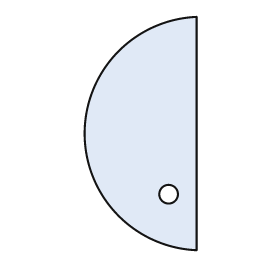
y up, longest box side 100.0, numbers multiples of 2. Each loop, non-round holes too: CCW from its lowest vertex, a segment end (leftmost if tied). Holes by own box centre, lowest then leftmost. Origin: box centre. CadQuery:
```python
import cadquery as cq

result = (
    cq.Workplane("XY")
    .moveTo(24.0, -50.0)
    .lineTo(24.0, 50.0)
    .threePointArc((-24.0, 0.0), (24.0, -50.0))
    .close()
    .moveTo(12.0, -26.0)
    .circle(4.0)
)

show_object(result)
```